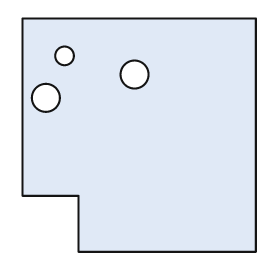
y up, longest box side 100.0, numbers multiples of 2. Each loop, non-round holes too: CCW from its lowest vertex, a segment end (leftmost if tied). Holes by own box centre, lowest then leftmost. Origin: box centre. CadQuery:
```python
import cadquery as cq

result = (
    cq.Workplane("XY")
    .moveTo(-26.0, -50.0)
    .lineTo(50.0, -50.0)
    .lineTo(50.0, 50.0)
    .lineTo(-50.0, 50.0)
    .lineTo(-50.0, -26.0)
    .lineTo(-26.0, -26.0)
    .close()
    .moveTo(-40.0, 16.0)
    .circle(6.0)
    .moveTo(-2.0, 26.0)
    .circle(6.0)
    .moveTo(-32.0, 34.0)
    .circle(4.0)
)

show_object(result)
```